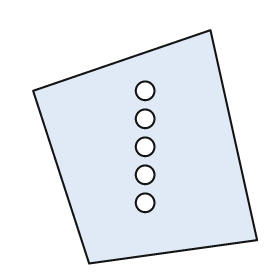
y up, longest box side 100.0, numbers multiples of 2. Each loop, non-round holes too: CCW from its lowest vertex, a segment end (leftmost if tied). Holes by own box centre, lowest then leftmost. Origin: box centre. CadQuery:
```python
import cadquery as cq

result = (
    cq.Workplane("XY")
    .moveTo(-24.0, -50.0)
    .lineTo(48.0, -40.0)
    .lineTo(28.0, 50.0)
    .lineTo(-48.0, 24.0)
    .close()
    .moveTo(0.0, -24.0)
    .circle(4.0)
    .moveTo(0.0, -12.0)
    .circle(4.0)
    .moveTo(0.0, 0.0)
    .circle(4.0)
    .moveTo(0.0, 12.0)
    .circle(4.0)
    .moveTo(0.0, 24.0)
    .circle(4.0)
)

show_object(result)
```